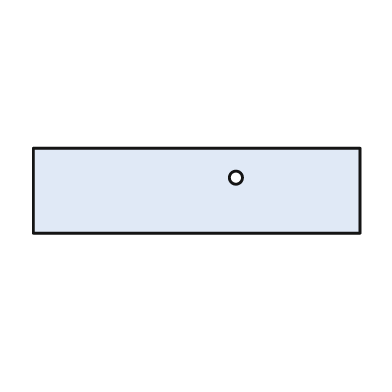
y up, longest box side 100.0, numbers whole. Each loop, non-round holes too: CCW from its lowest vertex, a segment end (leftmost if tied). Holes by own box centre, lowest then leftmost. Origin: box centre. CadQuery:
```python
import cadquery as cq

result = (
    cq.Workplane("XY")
    .moveTo(-50.0, -13.0)
    .lineTo(50.0, -13.0)
    .lineTo(50.0, 13.0)
    .lineTo(-50.0, 13.0)
    .close()
    .moveTo(12.0, 4.0)
    .circle(2.0)
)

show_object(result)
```